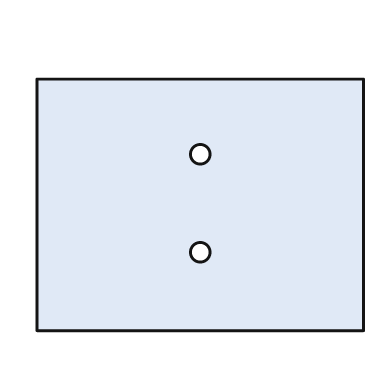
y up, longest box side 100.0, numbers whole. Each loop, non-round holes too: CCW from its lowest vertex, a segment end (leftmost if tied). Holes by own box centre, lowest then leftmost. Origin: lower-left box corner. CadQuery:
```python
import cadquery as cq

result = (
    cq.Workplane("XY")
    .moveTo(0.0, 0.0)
    .lineTo(100.0, 0.0)
    .lineTo(100.0, 77.0)
    .lineTo(0.0, 77.0)
    .close()
    .moveTo(50.0, 24.0)
    .circle(3.0)
    .moveTo(50.0, 54.0)
    .circle(3.0)
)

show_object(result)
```